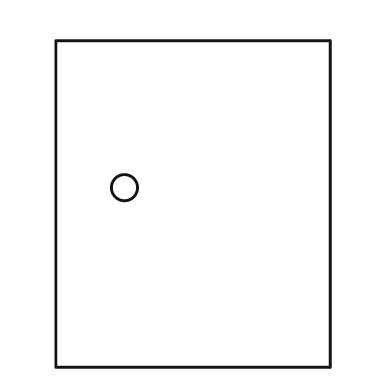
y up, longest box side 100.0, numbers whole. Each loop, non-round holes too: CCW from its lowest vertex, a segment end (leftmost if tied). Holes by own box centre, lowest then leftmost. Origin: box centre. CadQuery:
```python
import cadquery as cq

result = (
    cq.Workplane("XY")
    .moveTo(-42.0, -50.0)
    .lineTo(42.0, -50.0)
    .lineTo(42.0, 50.0)
    .lineTo(-42.0, 50.0)
    .close()
    .moveTo(-21.0, 5.0)
    .circle(4.0)
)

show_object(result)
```